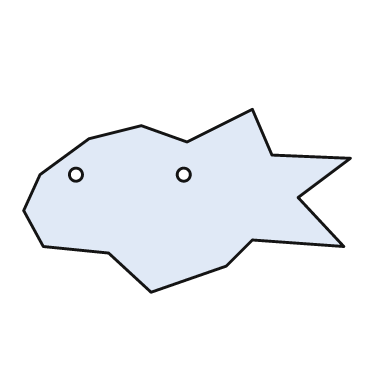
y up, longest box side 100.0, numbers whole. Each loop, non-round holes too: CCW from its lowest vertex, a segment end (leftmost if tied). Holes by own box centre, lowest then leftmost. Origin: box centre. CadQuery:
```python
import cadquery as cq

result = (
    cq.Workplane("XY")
    .moveTo(-11.0, -28.0)
    .lineTo(12.0, -20.0)
    .lineTo(20.0, -12.0)
    .lineTo(48.0, -14.0)
    .lineTo(34.0, 1.0)
    .lineTo(50.0, 13.0)
    .lineTo(26.0, 14.0)
    .lineTo(20.0, 28.0)
    .lineTo(0.0, 18.0)
    .lineTo(-14.0, 23.0)
    .lineTo(-30.0, 19.0)
    .lineTo(-45.0, 8.0)
    .lineTo(-50.0, -3.0)
    .lineTo(-44.0, -14.0)
    .lineTo(-24.0, -16.0)
    .close()
    .moveTo(-34.0, 8.0)
    .circle(2.0)
    .moveTo(-1.0, 8.0)
    .circle(2.0)
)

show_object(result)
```